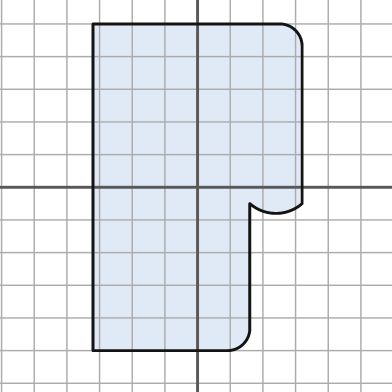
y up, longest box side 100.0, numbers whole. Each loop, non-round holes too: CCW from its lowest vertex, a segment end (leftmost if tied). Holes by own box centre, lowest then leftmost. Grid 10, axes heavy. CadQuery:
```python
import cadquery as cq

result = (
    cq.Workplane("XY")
    .moveTo(-32.0, -50.0)
    .lineTo(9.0, -50.0)
    .threePointArc((14.0, -48.0), (16.0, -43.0))
    .lineTo(16.0, -5.0)
    .threePointArc((24.0, -8.0), (32.0, -5.0))
    .lineTo(32.0, 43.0)
    .threePointArc((30.0, 48.0), (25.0, 50.0))
    .lineTo(-32.0, 50.0)
    .close()
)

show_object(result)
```